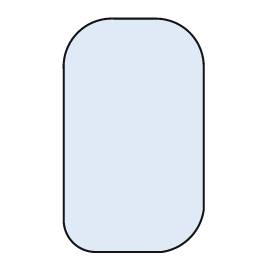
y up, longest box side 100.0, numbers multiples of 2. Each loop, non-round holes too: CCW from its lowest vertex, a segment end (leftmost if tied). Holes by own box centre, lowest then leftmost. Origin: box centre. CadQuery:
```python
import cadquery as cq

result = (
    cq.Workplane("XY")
    .moveTo(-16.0, -50.0)
    .lineTo(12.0, -50.0)
    .threePointArc((24.0, -44.0), (30.0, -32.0))
    .lineTo(30.0, 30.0)
    .threePointArc((24.0, 44.0), (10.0, 50.0))
    .lineTo(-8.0, 50.0)
    .threePointArc((-24.0, 44.0), (-30.0, 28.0))
    .lineTo(-30.0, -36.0)
    .threePointArc((-26.0, -46.0), (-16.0, -50.0))
    .close()
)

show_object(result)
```